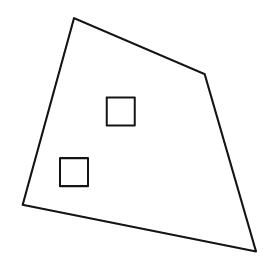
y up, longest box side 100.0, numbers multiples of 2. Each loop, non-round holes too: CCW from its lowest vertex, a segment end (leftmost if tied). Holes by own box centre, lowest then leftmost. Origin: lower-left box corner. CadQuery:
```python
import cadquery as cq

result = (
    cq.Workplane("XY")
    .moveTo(100.0, 0.0)
    .lineTo(78.0, 76.0)
    .lineTo(22.0, 100.0)
    .lineTo(0.0, 20.0)
    .close()
    .moveTo(16.0, 28.0)
    .lineTo(28.0, 28.0)
    .lineTo(28.0, 40.0)
    .lineTo(16.0, 40.0)
    .close()
    .moveTo(36.0, 54.0)
    .lineTo(48.0, 54.0)
    .lineTo(48.0, 66.0)
    .lineTo(36.0, 66.0)
    .close()
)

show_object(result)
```